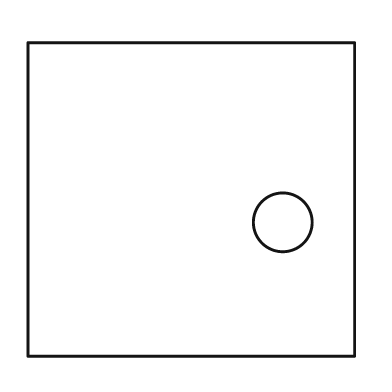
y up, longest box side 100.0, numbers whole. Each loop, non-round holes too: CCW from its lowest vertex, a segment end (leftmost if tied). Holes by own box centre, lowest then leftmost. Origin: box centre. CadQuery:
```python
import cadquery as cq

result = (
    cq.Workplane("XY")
    .moveTo(-50.0, -48.0)
    .lineTo(50.0, -48.0)
    .lineTo(50.0, 48.0)
    .lineTo(-50.0, 48.0)
    .close()
    .moveTo(28.0, -7.0)
    .circle(9.0)
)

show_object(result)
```